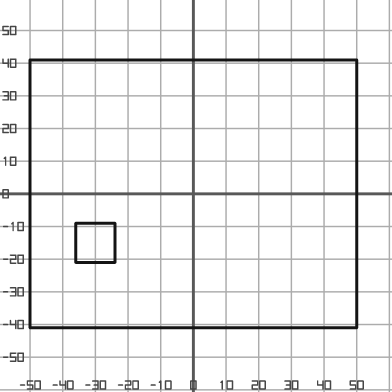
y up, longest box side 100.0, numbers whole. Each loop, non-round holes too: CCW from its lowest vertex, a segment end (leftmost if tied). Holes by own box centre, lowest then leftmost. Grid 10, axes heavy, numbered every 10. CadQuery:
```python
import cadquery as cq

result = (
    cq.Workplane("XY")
    .moveTo(-50.0, -41.0)
    .lineTo(50.0, -41.0)
    .lineTo(50.0, 41.0)
    .lineTo(-50.0, 41.0)
    .close()
    .moveTo(-36.0, -21.0)
    .lineTo(-24.0, -21.0)
    .lineTo(-24.0, -9.0)
    .lineTo(-36.0, -9.0)
    .close()
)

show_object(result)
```